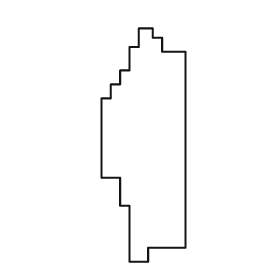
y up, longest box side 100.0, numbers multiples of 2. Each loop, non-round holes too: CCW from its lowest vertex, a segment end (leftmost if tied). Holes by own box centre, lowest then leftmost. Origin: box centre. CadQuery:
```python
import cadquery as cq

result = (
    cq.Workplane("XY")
    .moveTo(-6.0, -50.0)
    .lineTo(2.0, -50.0)
    .lineTo(2.0, -44.0)
    .lineTo(18.0, -44.0)
    .lineTo(18.0, 40.0)
    .lineTo(8.0, 40.0)
    .lineTo(8.0, 46.0)
    .lineTo(4.0, 46.0)
    .lineTo(4.0, 50.0)
    .lineTo(-2.0, 50.0)
    .lineTo(-2.0, 42.0)
    .lineTo(-6.0, 42.0)
    .lineTo(-6.0, 32.0)
    .lineTo(-10.0, 32.0)
    .lineTo(-10.0, 26.0)
    .lineTo(-14.0, 26.0)
    .lineTo(-14.0, 20.0)
    .lineTo(-18.0, 20.0)
    .lineTo(-18.0, -14.0)
    .lineTo(-10.0, -14.0)
    .lineTo(-10.0, -26.0)
    .lineTo(-6.0, -26.0)
    .close()
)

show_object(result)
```